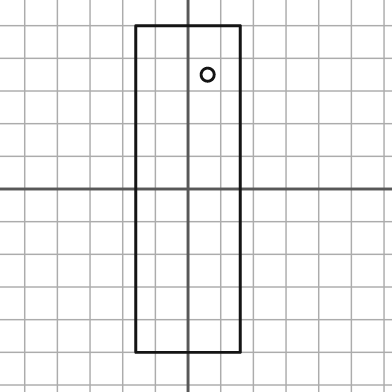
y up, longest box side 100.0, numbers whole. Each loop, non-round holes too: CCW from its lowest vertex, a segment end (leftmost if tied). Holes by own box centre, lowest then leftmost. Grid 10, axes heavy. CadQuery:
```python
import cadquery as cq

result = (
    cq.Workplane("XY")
    .moveTo(-16.0, -50.0)
    .lineTo(16.0, -50.0)
    .lineTo(16.0, 50.0)
    .lineTo(-16.0, 50.0)
    .close()
    .moveTo(6.0, 35.0)
    .circle(2.0)
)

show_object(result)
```